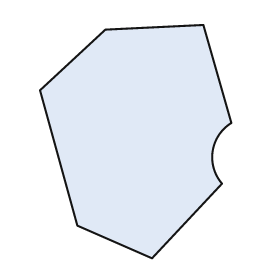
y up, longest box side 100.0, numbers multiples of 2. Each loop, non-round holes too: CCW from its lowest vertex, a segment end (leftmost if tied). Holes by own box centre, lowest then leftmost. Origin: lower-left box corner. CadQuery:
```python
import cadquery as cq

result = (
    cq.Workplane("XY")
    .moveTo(48.0, 0.0)
    .lineTo(78.0, 32.0)
    .threePointArc((74.0, 46.0), (82.0, 58.0))
    .lineTo(70.0, 100.0)
    .lineTo(28.0, 98.0)
    .lineTo(0.0, 72.0)
    .lineTo(16.0, 14.0)
    .close()
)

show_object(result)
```